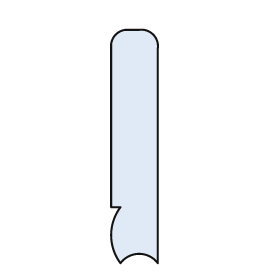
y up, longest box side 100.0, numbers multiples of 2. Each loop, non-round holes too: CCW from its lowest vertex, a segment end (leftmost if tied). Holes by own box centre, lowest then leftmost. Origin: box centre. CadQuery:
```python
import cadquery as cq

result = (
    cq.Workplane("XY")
    .moveTo(-6.0, -50.0)
    .threePointArc((2.0, -46.0), (10.0, -50.0))
    .lineTo(10.0, 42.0)
    .threePointArc((8.0, 48.0), (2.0, 50.0))
    .lineTo(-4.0, 50.0)
    .threePointArc((-8.0, 48.0), (-10.0, 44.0))
    .lineTo(-10.0, -26.0)
    .lineTo(-6.0, -26.0)
    .threePointArc((-10.0, -38.0), (-6.0, -50.0))
    .close()
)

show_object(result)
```